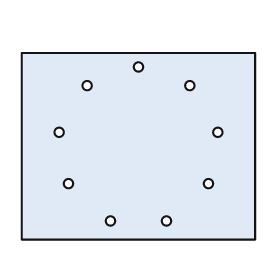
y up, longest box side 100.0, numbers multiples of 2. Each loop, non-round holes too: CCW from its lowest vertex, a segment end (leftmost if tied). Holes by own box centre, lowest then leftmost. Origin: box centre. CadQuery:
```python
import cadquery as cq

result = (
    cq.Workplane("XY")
    .moveTo(-50.0, -40.0)
    .lineTo(50.0, -40.0)
    .lineTo(50.0, 40.0)
    .lineTo(-50.0, 40.0)
    .close()
    .moveTo(-12.0, -32.0)
    .circle(2.0)
    .moveTo(12.0, -32.0)
    .circle(2.0)
    .moveTo(-30.0, -16.0)
    .circle(2.0)
    .moveTo(30.0, -16.0)
    .circle(2.0)
    .moveTo(-34.0, 6.0)
    .circle(2.0)
    .moveTo(34.0, 6.0)
    .circle(2.0)
    .moveTo(-22.0, 26.0)
    .circle(2.0)
    .moveTo(22.0, 26.0)
    .circle(2.0)
    .moveTo(0.0, 34.0)
    .circle(2.0)
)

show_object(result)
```